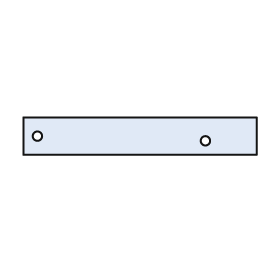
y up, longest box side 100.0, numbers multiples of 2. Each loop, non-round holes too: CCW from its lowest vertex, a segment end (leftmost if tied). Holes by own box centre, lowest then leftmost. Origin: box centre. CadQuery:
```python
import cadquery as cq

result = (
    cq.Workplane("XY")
    .moveTo(-50.0, -8.0)
    .lineTo(50.0, -8.0)
    .lineTo(50.0, 8.0)
    .lineTo(-50.0, 8.0)
    .close()
    .moveTo(28.0, -2.0)
    .circle(2.0)
    .moveTo(-44.0, 0.0)
    .circle(2.0)
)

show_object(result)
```